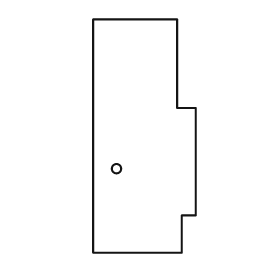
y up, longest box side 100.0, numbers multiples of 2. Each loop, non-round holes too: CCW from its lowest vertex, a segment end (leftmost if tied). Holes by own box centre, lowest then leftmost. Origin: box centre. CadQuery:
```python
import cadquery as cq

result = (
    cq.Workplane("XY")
    .moveTo(-22.0, -50.0)
    .lineTo(16.0, -50.0)
    .lineTo(16.0, -34.0)
    .lineTo(22.0, -34.0)
    .lineTo(22.0, 12.0)
    .lineTo(14.0, 12.0)
    .lineTo(14.0, 50.0)
    .lineTo(-22.0, 50.0)
    .close()
    .moveTo(-12.0, -14.0)
    .circle(2.0)
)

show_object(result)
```